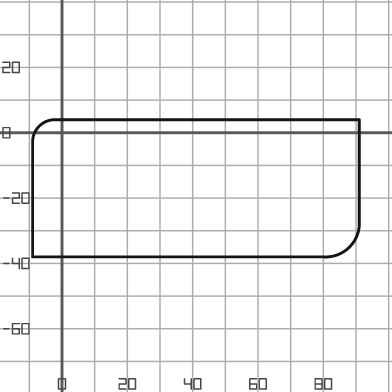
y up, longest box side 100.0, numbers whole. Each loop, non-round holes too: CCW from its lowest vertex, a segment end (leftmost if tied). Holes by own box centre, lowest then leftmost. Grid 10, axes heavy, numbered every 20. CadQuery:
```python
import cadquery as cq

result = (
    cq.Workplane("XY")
    .moveTo(-9.0, -38.0)
    .lineTo(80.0, -38.0)
    .threePointArc((88.0, -35.0), (91.0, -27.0))
    .lineTo(91.0, 4.0)
    .lineTo(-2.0, 4.0)
    .threePointArc((-7.0, 2.0), (-9.0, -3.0))
    .close()
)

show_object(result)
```